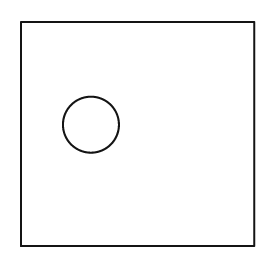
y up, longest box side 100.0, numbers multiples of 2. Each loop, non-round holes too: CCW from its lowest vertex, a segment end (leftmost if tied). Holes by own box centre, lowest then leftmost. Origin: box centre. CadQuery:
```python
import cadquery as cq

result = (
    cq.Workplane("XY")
    .moveTo(-50.0, -48.0)
    .lineTo(50.0, -48.0)
    .lineTo(50.0, 48.0)
    .lineTo(-50.0, 48.0)
    .close()
    .moveTo(-20.0, 4.0)
    .circle(12.0)
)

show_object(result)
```